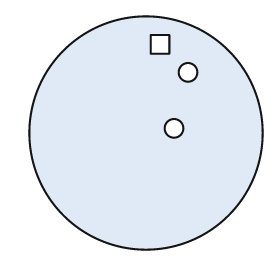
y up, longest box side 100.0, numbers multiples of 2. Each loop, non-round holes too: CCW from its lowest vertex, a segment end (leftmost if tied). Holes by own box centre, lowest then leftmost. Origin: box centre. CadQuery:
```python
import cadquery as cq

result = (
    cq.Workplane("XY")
    .moveTo(0.0, 0.0)
    .circle(50.0)
    .moveTo(12.0, 2.0)
    .circle(4.0)
    .moveTo(18.0, 26.0)
    .circle(4.0)
    .moveTo(2.0, 34.0)
    .lineTo(10.0, 34.0)
    .lineTo(10.0, 42.0)
    .lineTo(2.0, 42.0)
    .close()
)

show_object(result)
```